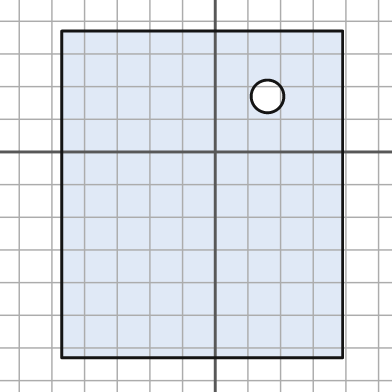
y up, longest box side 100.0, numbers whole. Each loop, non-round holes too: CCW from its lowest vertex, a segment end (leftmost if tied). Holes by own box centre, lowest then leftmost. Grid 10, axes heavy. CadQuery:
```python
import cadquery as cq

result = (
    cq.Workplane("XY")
    .moveTo(-47.0, -63.0)
    .lineTo(39.0, -63.0)
    .lineTo(39.0, 37.0)
    .lineTo(-47.0, 37.0)
    .close()
    .moveTo(16.0, 17.0)
    .circle(5.0)
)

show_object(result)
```